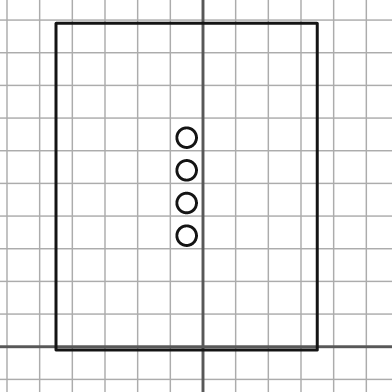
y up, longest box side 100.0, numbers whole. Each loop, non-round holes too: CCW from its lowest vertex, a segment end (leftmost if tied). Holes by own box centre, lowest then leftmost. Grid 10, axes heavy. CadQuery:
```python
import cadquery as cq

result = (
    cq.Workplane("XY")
    .moveTo(-45.0, -1.0)
    .lineTo(35.0, -1.0)
    .lineTo(35.0, 99.0)
    .lineTo(-45.0, 99.0)
    .close()
    .moveTo(-5.0, 34.0)
    .circle(3.0)
    .moveTo(-5.0, 44.0)
    .circle(3.0)
    .moveTo(-5.0, 54.0)
    .circle(3.0)
    .moveTo(-5.0, 64.0)
    .circle(3.0)
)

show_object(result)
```